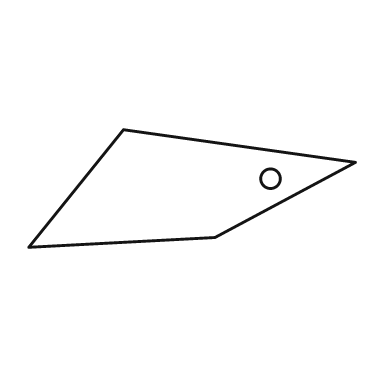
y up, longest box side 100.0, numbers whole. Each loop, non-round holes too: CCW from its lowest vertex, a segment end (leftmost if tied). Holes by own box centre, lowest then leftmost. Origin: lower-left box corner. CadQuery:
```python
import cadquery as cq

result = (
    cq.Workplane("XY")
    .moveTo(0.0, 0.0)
    .lineTo(57.0, 3.0)
    .lineTo(100.0, 26.0)
    .lineTo(29.0, 36.0)
    .close()
    .moveTo(74.0, 21.0)
    .circle(3.0)
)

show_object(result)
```